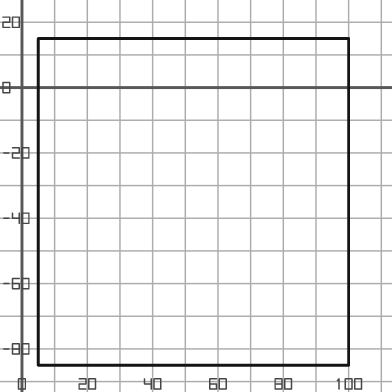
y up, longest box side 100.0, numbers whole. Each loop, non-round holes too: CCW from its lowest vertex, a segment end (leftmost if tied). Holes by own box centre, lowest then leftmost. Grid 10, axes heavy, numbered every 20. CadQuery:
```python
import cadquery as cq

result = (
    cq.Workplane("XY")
    .moveTo(5.0, -85.0)
    .lineTo(100.0, -85.0)
    .lineTo(100.0, 15.0)
    .lineTo(5.0, 15.0)
    .close()
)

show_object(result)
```